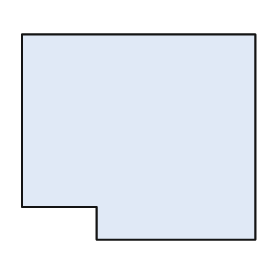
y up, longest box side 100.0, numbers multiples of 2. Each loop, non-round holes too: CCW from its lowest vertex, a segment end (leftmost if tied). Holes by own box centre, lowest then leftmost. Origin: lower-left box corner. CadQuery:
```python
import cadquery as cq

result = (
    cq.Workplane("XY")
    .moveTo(32.0, 0.0)
    .lineTo(100.0, 0.0)
    .lineTo(100.0, 88.0)
    .lineTo(0.0, 88.0)
    .lineTo(0.0, 14.0)
    .lineTo(32.0, 14.0)
    .close()
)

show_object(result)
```